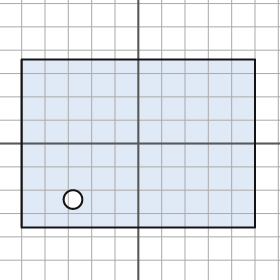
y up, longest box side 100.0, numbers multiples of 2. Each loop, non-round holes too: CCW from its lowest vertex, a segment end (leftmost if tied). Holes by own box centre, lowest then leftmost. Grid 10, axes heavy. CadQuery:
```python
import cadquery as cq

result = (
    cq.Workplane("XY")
    .moveTo(-50.0, -36.0)
    .lineTo(50.0, -36.0)
    .lineTo(50.0, 36.0)
    .lineTo(-50.0, 36.0)
    .close()
    .moveTo(-28.0, -24.0)
    .circle(4.0)
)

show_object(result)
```